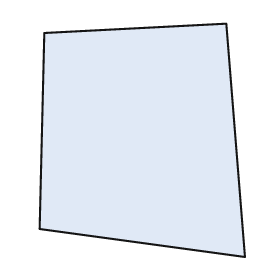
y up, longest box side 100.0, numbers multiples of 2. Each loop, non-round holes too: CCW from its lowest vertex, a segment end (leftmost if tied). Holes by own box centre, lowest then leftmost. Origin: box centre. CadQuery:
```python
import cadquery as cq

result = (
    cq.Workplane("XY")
    .moveTo(44.0, -50.0)
    .lineTo(36.0, 50.0)
    .lineTo(-42.0, 46.0)
    .lineTo(-44.0, -38.0)
    .close()
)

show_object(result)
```